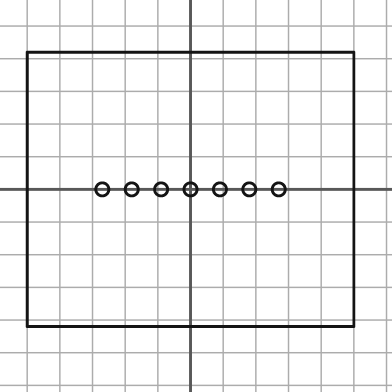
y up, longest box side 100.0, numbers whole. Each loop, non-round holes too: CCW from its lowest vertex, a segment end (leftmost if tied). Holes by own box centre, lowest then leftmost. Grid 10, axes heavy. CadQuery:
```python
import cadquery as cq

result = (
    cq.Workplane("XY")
    .moveTo(-50.0, -42.0)
    .lineTo(50.0, -42.0)
    .lineTo(50.0, 42.0)
    .lineTo(-50.0, 42.0)
    .close()
    .moveTo(-27.0, 0.0)
    .circle(2.0)
    .moveTo(-18.0, 0.0)
    .circle(2.0)
    .moveTo(-9.0, 0.0)
    .circle(2.0)
    .moveTo(0.0, 0.0)
    .circle(2.0)
    .moveTo(9.0, 0.0)
    .circle(2.0)
    .moveTo(18.0, 0.0)
    .circle(2.0)
    .moveTo(27.0, 0.0)
    .circle(2.0)
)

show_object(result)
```